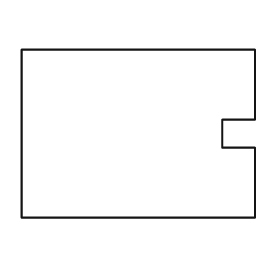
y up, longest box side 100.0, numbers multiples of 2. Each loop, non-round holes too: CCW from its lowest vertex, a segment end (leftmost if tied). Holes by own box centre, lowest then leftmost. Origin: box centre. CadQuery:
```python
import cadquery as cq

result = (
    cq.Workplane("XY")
    .moveTo(-50.0, -36.0)
    .lineTo(50.0, -36.0)
    .lineTo(50.0, -6.0)
    .lineTo(36.0, -6.0)
    .lineTo(36.0, 6.0)
    .lineTo(50.0, 6.0)
    .lineTo(50.0, 36.0)
    .lineTo(-50.0, 36.0)
    .close()
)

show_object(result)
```